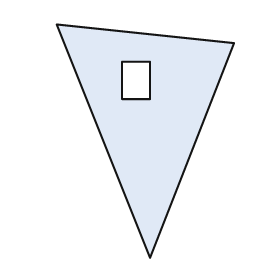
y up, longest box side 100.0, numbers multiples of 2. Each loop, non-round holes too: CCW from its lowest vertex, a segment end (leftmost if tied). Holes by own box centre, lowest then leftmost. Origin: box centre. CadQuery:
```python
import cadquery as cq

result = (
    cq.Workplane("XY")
    .moveTo(2.0, -50.0)
    .lineTo(38.0, 42.0)
    .lineTo(-38.0, 50.0)
    .close()
    .moveTo(-10.0, 18.0)
    .lineTo(2.0, 18.0)
    .lineTo(2.0, 34.0)
    .lineTo(-10.0, 34.0)
    .close()
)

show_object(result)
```